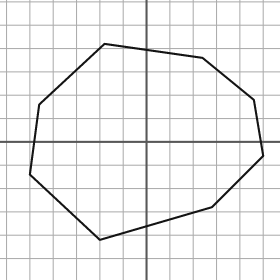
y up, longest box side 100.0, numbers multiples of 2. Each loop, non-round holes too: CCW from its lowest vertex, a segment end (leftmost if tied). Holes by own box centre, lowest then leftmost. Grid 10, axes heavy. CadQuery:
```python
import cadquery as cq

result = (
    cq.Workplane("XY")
    .moveTo(-20.0, -42.0)
    .lineTo(28.0, -28.0)
    .lineTo(50.0, -6.0)
    .lineTo(46.0, 18.0)
    .lineTo(24.0, 36.0)
    .lineTo(-18.0, 42.0)
    .lineTo(-46.0, 16.0)
    .lineTo(-50.0, -14.0)
    .close()
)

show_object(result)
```